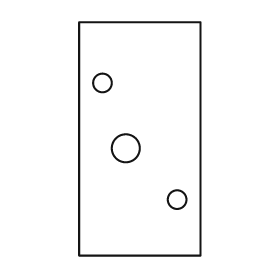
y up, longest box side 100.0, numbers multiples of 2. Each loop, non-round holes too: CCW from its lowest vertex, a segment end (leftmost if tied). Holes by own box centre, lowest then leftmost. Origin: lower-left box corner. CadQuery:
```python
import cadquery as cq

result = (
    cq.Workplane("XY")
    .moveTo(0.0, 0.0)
    .lineTo(52.0, 0.0)
    .lineTo(52.0, 100.0)
    .lineTo(0.0, 100.0)
    .close()
    .moveTo(42.0, 24.0)
    .circle(4.0)
    .moveTo(20.0, 46.0)
    .circle(6.0)
    .moveTo(10.0, 74.0)
    .circle(4.0)
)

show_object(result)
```